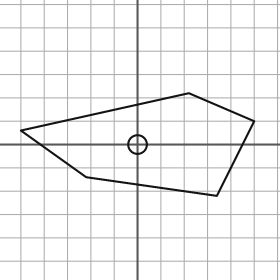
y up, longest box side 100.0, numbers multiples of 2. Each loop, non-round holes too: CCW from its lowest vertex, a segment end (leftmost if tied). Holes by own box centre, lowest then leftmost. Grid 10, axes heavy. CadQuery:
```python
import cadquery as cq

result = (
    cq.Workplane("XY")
    .moveTo(34.0, -22.0)
    .lineTo(50.0, 10.0)
    .lineTo(22.0, 22.0)
    .lineTo(-50.0, 6.0)
    .lineTo(-22.0, -14.0)
    .close()
    .moveTo(0.0, 0.0)
    .circle(4.0)
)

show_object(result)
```